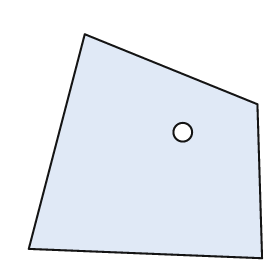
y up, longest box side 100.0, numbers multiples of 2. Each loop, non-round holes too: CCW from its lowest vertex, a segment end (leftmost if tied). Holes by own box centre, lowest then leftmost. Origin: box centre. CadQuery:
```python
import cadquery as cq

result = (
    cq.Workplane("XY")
    .moveTo(50.0, -48.0)
    .lineTo(48.0, 18.0)
    .lineTo(-26.0, 48.0)
    .lineTo(-50.0, -44.0)
    .close()
    .moveTo(16.0, 6.0)
    .circle(4.0)
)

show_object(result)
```